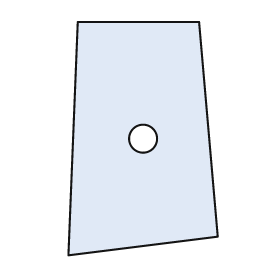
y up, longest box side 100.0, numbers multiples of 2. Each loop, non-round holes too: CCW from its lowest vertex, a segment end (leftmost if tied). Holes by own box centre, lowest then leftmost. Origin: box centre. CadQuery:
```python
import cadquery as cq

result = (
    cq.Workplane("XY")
    .moveTo(-32.0, -50.0)
    .lineTo(32.0, -42.0)
    .lineTo(24.0, 50.0)
    .lineTo(-28.0, 50.0)
    .close()
    .moveTo(0.0, 0.0)
    .circle(6.0)
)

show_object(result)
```